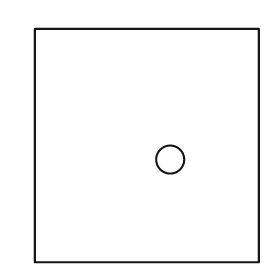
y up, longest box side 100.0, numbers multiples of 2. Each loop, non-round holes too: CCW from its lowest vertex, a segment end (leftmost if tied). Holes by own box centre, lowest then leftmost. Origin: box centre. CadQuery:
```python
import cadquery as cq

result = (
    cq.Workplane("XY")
    .moveTo(-48.0, -50.0)
    .lineTo(48.0, -50.0)
    .lineTo(48.0, 50.0)
    .lineTo(-48.0, 50.0)
    .close()
    .moveTo(10.0, -6.0)
    .circle(6.0)
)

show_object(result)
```